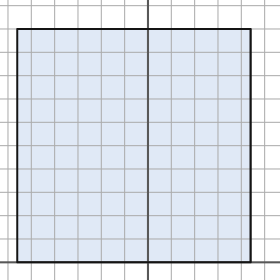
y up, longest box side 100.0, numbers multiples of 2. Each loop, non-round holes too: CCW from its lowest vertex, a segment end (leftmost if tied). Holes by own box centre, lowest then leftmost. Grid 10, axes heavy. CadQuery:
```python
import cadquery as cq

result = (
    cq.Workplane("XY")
    .moveTo(-56.0, 0.0)
    .lineTo(44.0, 0.0)
    .lineTo(44.0, 100.0)
    .lineTo(-56.0, 100.0)
    .close()
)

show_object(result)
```